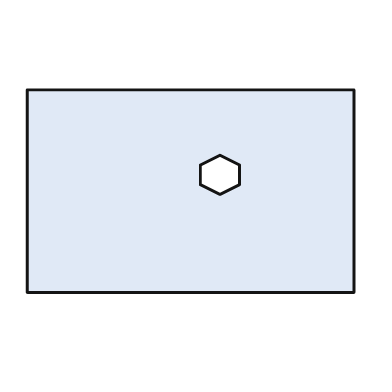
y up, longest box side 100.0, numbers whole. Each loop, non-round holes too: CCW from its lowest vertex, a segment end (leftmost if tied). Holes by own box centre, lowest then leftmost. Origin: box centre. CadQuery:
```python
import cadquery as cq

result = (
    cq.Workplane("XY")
    .moveTo(-50.0, -31.0)
    .lineTo(50.0, -31.0)
    .lineTo(50.0, 31.0)
    .lineTo(-50.0, 31.0)
    .close()
    .moveTo(9.0, -1.0)
    .lineTo(15.0, 2.0)
    .lineTo(15.0, 8.0)
    .lineTo(9.0, 11.0)
    .lineTo(3.0, 8.0)
    .lineTo(3.0, 2.0)
    .close()
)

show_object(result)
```